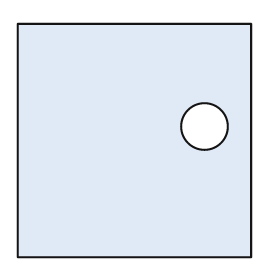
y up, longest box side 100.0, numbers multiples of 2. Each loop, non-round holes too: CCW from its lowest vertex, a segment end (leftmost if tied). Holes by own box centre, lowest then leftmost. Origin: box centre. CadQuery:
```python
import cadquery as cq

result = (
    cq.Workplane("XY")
    .moveTo(-50.0, -50.0)
    .lineTo(50.0, -50.0)
    .lineTo(50.0, 50.0)
    .lineTo(-50.0, 50.0)
    .close()
    .moveTo(30.0, 6.0)
    .circle(10.0)
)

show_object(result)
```